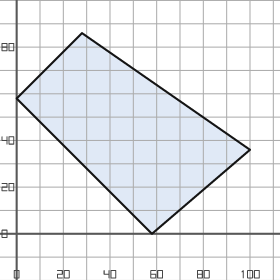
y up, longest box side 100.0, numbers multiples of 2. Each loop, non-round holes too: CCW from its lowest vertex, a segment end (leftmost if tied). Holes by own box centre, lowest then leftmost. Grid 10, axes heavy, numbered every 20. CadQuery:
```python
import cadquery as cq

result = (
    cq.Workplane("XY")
    .moveTo(58.0, 0.0)
    .lineTo(100.0, 36.0)
    .lineTo(28.0, 86.0)
    .lineTo(0.0, 58.0)
    .close()
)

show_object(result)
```